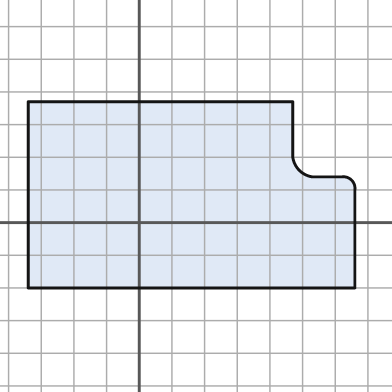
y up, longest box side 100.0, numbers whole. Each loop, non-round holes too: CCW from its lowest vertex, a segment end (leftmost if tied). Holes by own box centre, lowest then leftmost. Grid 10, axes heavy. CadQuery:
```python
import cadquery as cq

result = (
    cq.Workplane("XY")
    .moveTo(-34.0, -20.0)
    .lineTo(66.0, -20.0)
    .lineTo(66.0, 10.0)
    .threePointArc((65.0, 13.0), (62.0, 14.0))
    .lineTo(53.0, 14.0)
    .threePointArc((49.0, 16.0), (47.0, 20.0))
    .lineTo(47.0, 37.0)
    .lineTo(-34.0, 37.0)
    .close()
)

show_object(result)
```